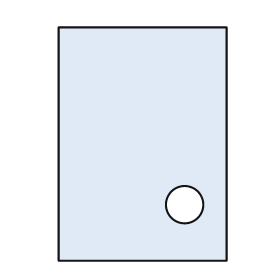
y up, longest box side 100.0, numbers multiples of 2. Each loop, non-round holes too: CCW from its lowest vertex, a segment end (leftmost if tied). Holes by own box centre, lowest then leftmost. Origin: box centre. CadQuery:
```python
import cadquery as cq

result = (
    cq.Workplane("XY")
    .moveTo(-36.0, -50.0)
    .lineTo(36.0, -50.0)
    .lineTo(36.0, 50.0)
    .lineTo(-36.0, 50.0)
    .close()
    .moveTo(18.0, -26.0)
    .circle(8.0)
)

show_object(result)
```